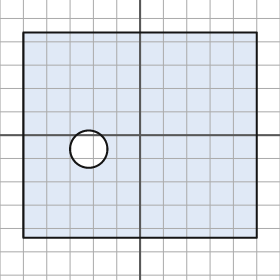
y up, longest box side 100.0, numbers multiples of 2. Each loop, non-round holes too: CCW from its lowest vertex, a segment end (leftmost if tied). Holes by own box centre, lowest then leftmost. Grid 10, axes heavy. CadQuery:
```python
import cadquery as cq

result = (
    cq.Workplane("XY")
    .moveTo(-50.0, -44.0)
    .lineTo(50.0, -44.0)
    .lineTo(50.0, 44.0)
    .lineTo(-50.0, 44.0)
    .close()
    .moveTo(-22.0, -6.0)
    .circle(8.0)
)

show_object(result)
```